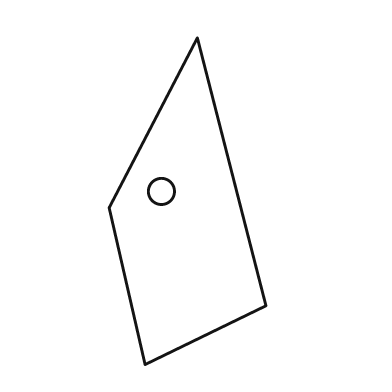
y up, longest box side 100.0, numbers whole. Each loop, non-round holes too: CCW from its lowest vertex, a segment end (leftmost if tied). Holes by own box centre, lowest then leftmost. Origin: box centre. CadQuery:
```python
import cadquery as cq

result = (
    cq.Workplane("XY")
    .moveTo(-13.0, -50.0)
    .lineTo(24.0, -32.0)
    .lineTo(3.0, 50.0)
    .lineTo(-24.0, -2.0)
    .close()
    .moveTo(-8.0, 3.0)
    .circle(4.0)
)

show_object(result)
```